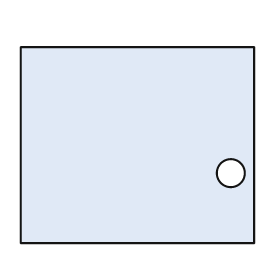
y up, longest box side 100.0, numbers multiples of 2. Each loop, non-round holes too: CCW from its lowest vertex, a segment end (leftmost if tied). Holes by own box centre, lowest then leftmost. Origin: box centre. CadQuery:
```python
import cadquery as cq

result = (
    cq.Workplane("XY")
    .moveTo(-50.0, -42.0)
    .lineTo(50.0, -42.0)
    .lineTo(50.0, 42.0)
    .lineTo(-50.0, 42.0)
    .close()
    .moveTo(40.0, -12.0)
    .circle(6.0)
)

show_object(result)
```